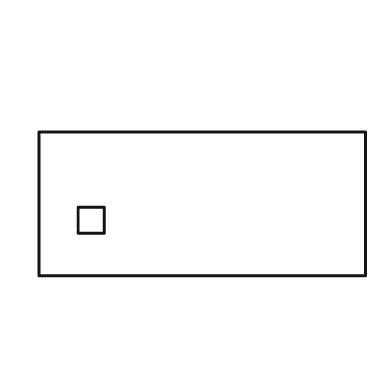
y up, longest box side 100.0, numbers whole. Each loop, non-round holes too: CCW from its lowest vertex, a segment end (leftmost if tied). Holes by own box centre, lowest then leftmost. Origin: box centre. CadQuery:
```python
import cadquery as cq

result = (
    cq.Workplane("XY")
    .moveTo(-50.0, -22.0)
    .lineTo(50.0, -22.0)
    .lineTo(50.0, 22.0)
    .lineTo(-50.0, 22.0)
    .close()
    .moveTo(-38.0, -9.0)
    .lineTo(-30.0, -9.0)
    .lineTo(-30.0, -1.0)
    .lineTo(-38.0, -1.0)
    .close()
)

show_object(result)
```